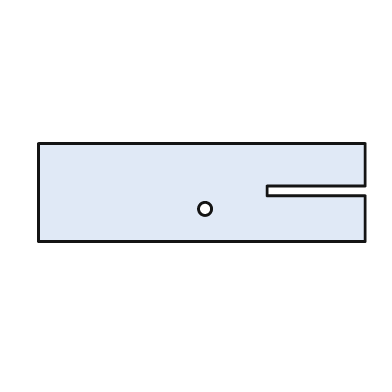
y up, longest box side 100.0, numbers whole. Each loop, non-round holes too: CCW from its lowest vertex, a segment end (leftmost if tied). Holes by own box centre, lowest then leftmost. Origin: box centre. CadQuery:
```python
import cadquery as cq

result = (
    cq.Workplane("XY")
    .moveTo(-50.0, -15.0)
    .lineTo(50.0, -15.0)
    .lineTo(50.0, -1.0)
    .lineTo(20.0, -1.0)
    .lineTo(20.0, 2.0)
    .lineTo(50.0, 2.0)
    .lineTo(50.0, 15.0)
    .lineTo(-50.0, 15.0)
    .close()
    .moveTo(1.0, -5.0)
    .circle(2.0)
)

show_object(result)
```